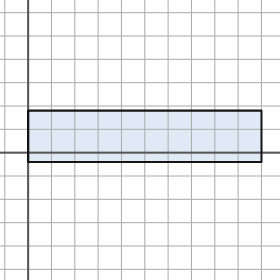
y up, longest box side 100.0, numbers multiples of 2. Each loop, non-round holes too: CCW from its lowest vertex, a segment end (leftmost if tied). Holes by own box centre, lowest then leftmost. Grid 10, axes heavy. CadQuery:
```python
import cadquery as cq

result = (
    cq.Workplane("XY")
    .moveTo(0.0, -4.0)
    .lineTo(100.0, -4.0)
    .lineTo(100.0, 18.0)
    .lineTo(0.0, 18.0)
    .close()
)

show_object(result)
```